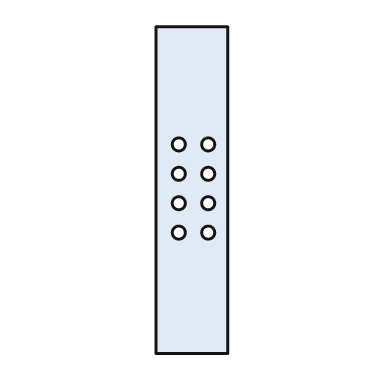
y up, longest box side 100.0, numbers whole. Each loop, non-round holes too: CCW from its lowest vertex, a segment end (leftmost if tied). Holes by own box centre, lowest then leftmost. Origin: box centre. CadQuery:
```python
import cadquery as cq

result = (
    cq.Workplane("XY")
    .moveTo(-11.0, -50.0)
    .lineTo(11.0, -50.0)
    .lineTo(11.0, 50.0)
    .lineTo(-11.0, 50.0)
    .close()
    .moveTo(-4.0, -13.0)
    .circle(2.0)
    .moveTo(5.0, -13.0)
    .circle(2.0)
    .moveTo(-4.0, -4.0)
    .circle(2.0)
    .moveTo(5.0, -4.0)
    .circle(2.0)
    .moveTo(-4.0, 5.0)
    .circle(2.0)
    .moveTo(5.0, 5.0)
    .circle(2.0)
    .moveTo(-4.0, 14.0)
    .circle(2.0)
    .moveTo(5.0, 14.0)
    .circle(2.0)
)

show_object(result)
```